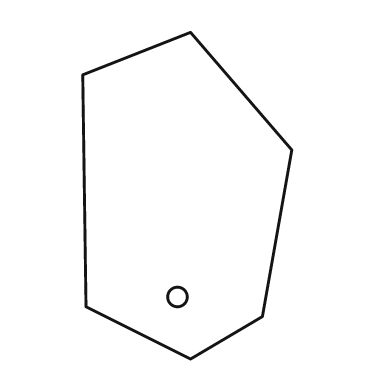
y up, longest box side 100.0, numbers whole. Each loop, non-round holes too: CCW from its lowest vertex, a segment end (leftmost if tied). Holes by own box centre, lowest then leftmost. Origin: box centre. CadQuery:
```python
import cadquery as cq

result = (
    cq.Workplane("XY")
    .moveTo(1.0, -50.0)
    .lineTo(23.0, -37.0)
    .lineTo(32.0, 14.0)
    .lineTo(1.0, 50.0)
    .lineTo(-32.0, 37.0)
    .lineTo(-31.0, -34.0)
    .close()
    .moveTo(-3.0, -31.0)
    .circle(3.0)
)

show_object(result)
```